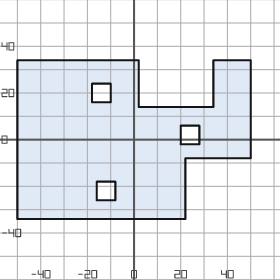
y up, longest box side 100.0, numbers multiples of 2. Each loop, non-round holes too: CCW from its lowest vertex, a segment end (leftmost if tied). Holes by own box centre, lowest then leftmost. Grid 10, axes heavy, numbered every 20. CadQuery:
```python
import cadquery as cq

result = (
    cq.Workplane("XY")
    .moveTo(-50.0, -34.0)
    .lineTo(22.0, -34.0)
    .lineTo(22.0, -8.0)
    .lineTo(50.0, -8.0)
    .lineTo(50.0, 34.0)
    .lineTo(34.0, 34.0)
    .lineTo(34.0, 14.0)
    .lineTo(2.0, 14.0)
    .lineTo(2.0, 34.0)
    .lineTo(-50.0, 34.0)
    .close()
    .moveTo(-16.0, -26.0)
    .lineTo(-8.0, -26.0)
    .lineTo(-8.0, -18.0)
    .lineTo(-16.0, -18.0)
    .close()
    .moveTo(20.0, -2.0)
    .lineTo(28.0, -2.0)
    .lineTo(28.0, 6.0)
    .lineTo(20.0, 6.0)
    .close()
    .moveTo(-18.0, 16.0)
    .lineTo(-10.0, 16.0)
    .lineTo(-10.0, 24.0)
    .lineTo(-18.0, 24.0)
    .close()
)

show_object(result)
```